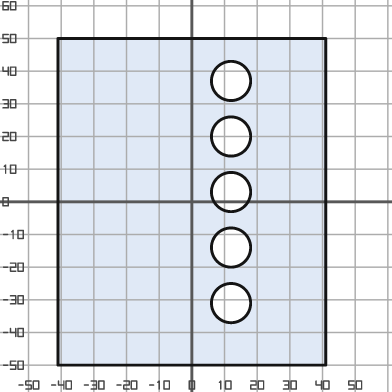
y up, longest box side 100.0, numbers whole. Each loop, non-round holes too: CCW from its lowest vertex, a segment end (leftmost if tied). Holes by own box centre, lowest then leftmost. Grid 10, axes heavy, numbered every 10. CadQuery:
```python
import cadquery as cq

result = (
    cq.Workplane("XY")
    .moveTo(-41.0, -50.0)
    .lineTo(41.0, -50.0)
    .lineTo(41.0, 50.0)
    .lineTo(-41.0, 50.0)
    .close()
    .moveTo(12.0, -31.0)
    .circle(6.0)
    .moveTo(12.0, -14.0)
    .circle(6.0)
    .moveTo(12.0, 3.0)
    .circle(6.0)
    .moveTo(12.0, 20.0)
    .circle(6.0)
    .moveTo(12.0, 37.0)
    .circle(6.0)
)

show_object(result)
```